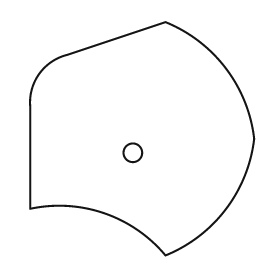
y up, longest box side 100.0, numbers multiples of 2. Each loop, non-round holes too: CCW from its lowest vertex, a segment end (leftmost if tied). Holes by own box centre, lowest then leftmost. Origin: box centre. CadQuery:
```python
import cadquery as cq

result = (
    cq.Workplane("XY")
    .moveTo(10.0, -50.0)
    .threePointArc((36.0, -30.0), (48.0, 0.0))
    .threePointArc((36.0, 30.0), (10.0, 50.0))
    .lineTo(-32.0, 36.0)
    .threePointArc((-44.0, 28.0), (-48.0, 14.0))
    .lineTo(-48.0, -30.0)
    .threePointArc((-16.0, -32.0), (10.0, -50.0))
    .close()
    .moveTo(-4.0, -6.0)
    .circle(4.0)
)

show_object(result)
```